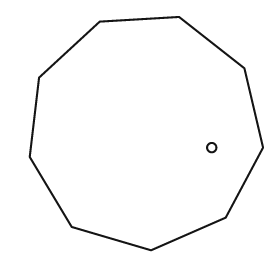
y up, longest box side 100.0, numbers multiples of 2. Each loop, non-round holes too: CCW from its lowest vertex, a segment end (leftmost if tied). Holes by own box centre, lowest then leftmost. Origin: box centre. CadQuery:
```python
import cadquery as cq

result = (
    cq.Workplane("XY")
    .moveTo(2.0, -50.0)
    .lineTo(34.0, -36.0)
    .lineTo(50.0, -6.0)
    .lineTo(42.0, 28.0)
    .lineTo(14.0, 50.0)
    .lineTo(-20.0, 48.0)
    .lineTo(-46.0, 24.0)
    .lineTo(-50.0, -10.0)
    .lineTo(-32.0, -40.0)
    .close()
    .moveTo(28.0, -6.0)
    .circle(2.0)
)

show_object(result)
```